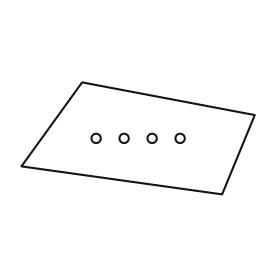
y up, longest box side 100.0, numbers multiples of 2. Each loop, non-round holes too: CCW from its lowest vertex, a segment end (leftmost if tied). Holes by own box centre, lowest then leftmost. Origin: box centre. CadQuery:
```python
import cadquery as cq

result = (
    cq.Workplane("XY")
    .moveTo(36.0, -24.0)
    .lineTo(50.0, 10.0)
    .lineTo(-24.0, 24.0)
    .lineTo(-50.0, -12.0)
    .close()
    .moveTo(-18.0, 0.0)
    .circle(2.0)
    .moveTo(-6.0, 0.0)
    .circle(2.0)
    .moveTo(6.0, 0.0)
    .circle(2.0)
    .moveTo(18.0, 0.0)
    .circle(2.0)
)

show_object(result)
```